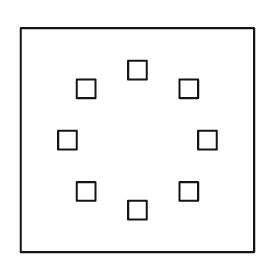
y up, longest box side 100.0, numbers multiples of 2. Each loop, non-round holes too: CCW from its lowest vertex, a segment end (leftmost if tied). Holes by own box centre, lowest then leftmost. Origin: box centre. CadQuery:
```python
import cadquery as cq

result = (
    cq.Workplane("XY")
    .moveTo(-50.0, -48.0)
    .lineTo(50.0, -48.0)
    .lineTo(50.0, 48.0)
    .lineTo(-50.0, 48.0)
    .close()
    .moveTo(-4.0, -34.0)
    .lineTo(4.0, -34.0)
    .lineTo(4.0, -26.0)
    .lineTo(-4.0, -26.0)
    .close()
    .moveTo(-26.0, -26.0)
    .lineTo(-18.0, -26.0)
    .lineTo(-18.0, -18.0)
    .lineTo(-26.0, -18.0)
    .close()
    .moveTo(18.0, -26.0)
    .lineTo(26.0, -26.0)
    .lineTo(26.0, -18.0)
    .lineTo(18.0, -18.0)
    .close()
    .moveTo(-34.0, -4.0)
    .lineTo(-26.0, -4.0)
    .lineTo(-26.0, 4.0)
    .lineTo(-34.0, 4.0)
    .close()
    .moveTo(26.0, -4.0)
    .lineTo(34.0, -4.0)
    .lineTo(34.0, 4.0)
    .lineTo(26.0, 4.0)
    .close()
    .moveTo(-26.0, 18.0)
    .lineTo(-18.0, 18.0)
    .lineTo(-18.0, 26.0)
    .lineTo(-26.0, 26.0)
    .close()
    .moveTo(18.0, 18.0)
    .lineTo(26.0, 18.0)
    .lineTo(26.0, 26.0)
    .lineTo(18.0, 26.0)
    .close()
    .moveTo(-4.0, 26.0)
    .lineTo(4.0, 26.0)
    .lineTo(4.0, 34.0)
    .lineTo(-4.0, 34.0)
    .close()
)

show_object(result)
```